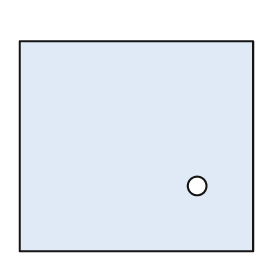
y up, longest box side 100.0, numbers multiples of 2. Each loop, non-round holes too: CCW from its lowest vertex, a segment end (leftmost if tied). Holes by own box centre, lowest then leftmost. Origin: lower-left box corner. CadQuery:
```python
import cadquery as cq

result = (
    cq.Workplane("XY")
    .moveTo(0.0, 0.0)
    .lineTo(100.0, 0.0)
    .lineTo(100.0, 90.0)
    .lineTo(0.0, 90.0)
    .close()
    .moveTo(76.0, 28.0)
    .circle(4.0)
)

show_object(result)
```